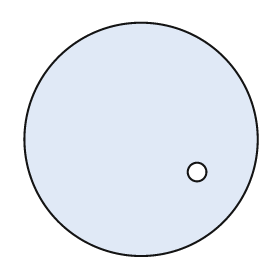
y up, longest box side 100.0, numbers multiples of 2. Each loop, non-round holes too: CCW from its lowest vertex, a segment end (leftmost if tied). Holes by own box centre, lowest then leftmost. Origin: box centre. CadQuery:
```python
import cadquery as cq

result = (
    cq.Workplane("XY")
    .moveTo(0.0, 0.0)
    .circle(50.0)
    .moveTo(24.0, -14.0)
    .circle(4.0)
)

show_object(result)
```